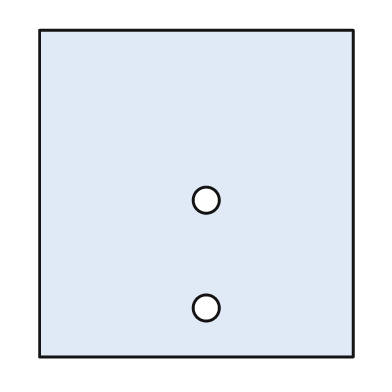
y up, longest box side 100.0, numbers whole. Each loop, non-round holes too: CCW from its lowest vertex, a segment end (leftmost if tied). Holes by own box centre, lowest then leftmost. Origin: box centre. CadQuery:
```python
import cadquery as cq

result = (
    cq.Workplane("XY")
    .moveTo(-48.0, -50.0)
    .lineTo(48.0, -50.0)
    .lineTo(48.0, 50.0)
    .lineTo(-48.0, 50.0)
    .close()
    .moveTo(3.0, -35.0)
    .circle(4.0)
    .moveTo(3.0, -2.0)
    .circle(4.0)
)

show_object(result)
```